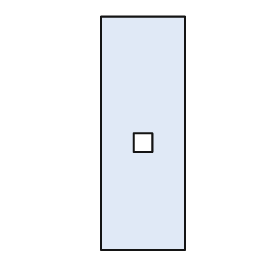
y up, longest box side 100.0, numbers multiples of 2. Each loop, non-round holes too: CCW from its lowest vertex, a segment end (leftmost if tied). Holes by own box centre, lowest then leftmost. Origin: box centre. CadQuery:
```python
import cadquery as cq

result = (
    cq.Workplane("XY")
    .moveTo(-18.0, -50.0)
    .lineTo(18.0, -50.0)
    .lineTo(18.0, 50.0)
    .lineTo(-18.0, 50.0)
    .close()
    .moveTo(-4.0, -8.0)
    .lineTo(4.0, -8.0)
    .lineTo(4.0, 0.0)
    .lineTo(-4.0, 0.0)
    .close()
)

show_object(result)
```